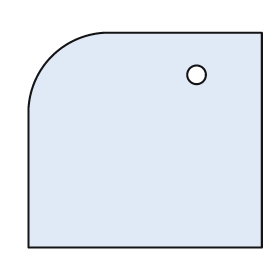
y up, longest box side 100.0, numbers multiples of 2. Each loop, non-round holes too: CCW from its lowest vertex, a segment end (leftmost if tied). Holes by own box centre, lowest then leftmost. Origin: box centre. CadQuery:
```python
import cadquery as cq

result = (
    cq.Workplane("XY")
    .moveTo(-50.0, -46.0)
    .lineTo(50.0, -46.0)
    .lineTo(50.0, 46.0)
    .lineTo(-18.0, 46.0)
    .threePointArc((-40.0, 36.0), (-50.0, 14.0))
    .close()
    .moveTo(22.0, 28.0)
    .circle(4.0)
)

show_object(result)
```